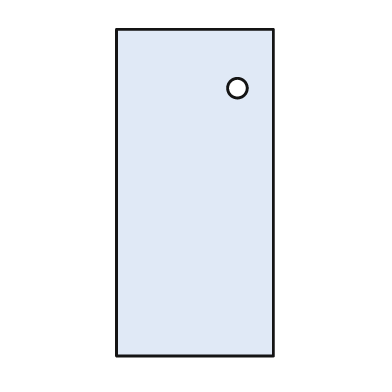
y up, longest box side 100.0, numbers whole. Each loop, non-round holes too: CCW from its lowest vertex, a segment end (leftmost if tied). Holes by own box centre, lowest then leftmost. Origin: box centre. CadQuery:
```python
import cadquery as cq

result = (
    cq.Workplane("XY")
    .moveTo(-24.0, -50.0)
    .lineTo(24.0, -50.0)
    .lineTo(24.0, 50.0)
    .lineTo(-24.0, 50.0)
    .close()
    .moveTo(13.0, 32.0)
    .circle(3.0)
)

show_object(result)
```